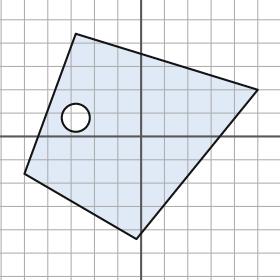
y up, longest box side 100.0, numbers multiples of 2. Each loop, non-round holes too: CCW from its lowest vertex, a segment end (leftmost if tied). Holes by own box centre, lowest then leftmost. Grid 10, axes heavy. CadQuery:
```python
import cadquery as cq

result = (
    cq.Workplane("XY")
    .moveTo(-2.0, -44.0)
    .lineTo(50.0, 20.0)
    .lineTo(-28.0, 44.0)
    .lineTo(-50.0, -16.0)
    .close()
    .moveTo(-28.0, 8.0)
    .circle(6.0)
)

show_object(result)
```